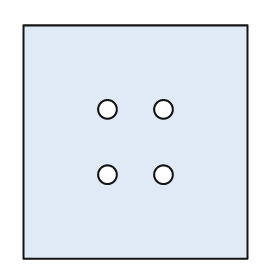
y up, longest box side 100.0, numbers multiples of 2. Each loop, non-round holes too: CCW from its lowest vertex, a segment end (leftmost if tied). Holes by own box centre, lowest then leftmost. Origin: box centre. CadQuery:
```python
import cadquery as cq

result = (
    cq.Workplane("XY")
    .moveTo(-48.0, -50.0)
    .lineTo(48.0, -50.0)
    .lineTo(48.0, 50.0)
    .lineTo(-48.0, 50.0)
    .close()
    .moveTo(-12.0, -14.0)
    .circle(4.0)
    .moveTo(12.0, -14.0)
    .circle(4.0)
    .moveTo(-12.0, 14.0)
    .circle(4.0)
    .moveTo(12.0, 14.0)
    .circle(4.0)
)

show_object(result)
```